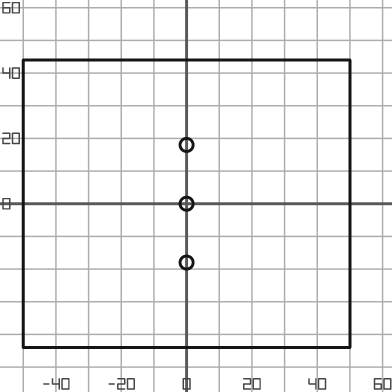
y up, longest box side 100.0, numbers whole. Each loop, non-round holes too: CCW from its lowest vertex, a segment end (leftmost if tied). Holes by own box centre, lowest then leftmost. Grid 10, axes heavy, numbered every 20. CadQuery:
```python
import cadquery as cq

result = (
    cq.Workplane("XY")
    .moveTo(-50.0, -44.0)
    .lineTo(50.0, -44.0)
    .lineTo(50.0, 44.0)
    .lineTo(-50.0, 44.0)
    .close()
    .moveTo(0.0, -18.0)
    .circle(2.0)
    .moveTo(0.0, 0.0)
    .circle(2.0)
    .moveTo(0.0, 18.0)
    .circle(2.0)
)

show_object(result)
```